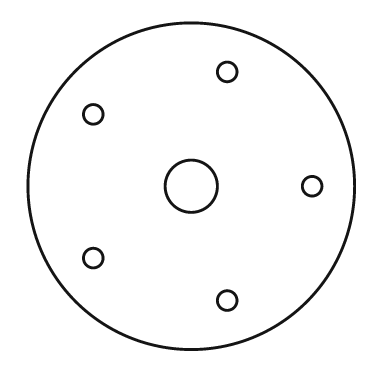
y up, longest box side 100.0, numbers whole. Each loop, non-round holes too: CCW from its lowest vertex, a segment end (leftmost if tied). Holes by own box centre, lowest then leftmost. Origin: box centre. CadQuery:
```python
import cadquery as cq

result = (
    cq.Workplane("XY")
    .moveTo(0.0, 0.0)
    .circle(50.0)
    .moveTo(11.0, -35.0)
    .circle(3.0)
    .moveTo(-30.0, -22.0)
    .circle(3.0)
    .moveTo(0.0, 0.0)
    .circle(8.0)
    .moveTo(37.0, 0.0)
    .circle(3.0)
    .moveTo(-30.0, 22.0)
    .circle(3.0)
    .moveTo(11.0, 35.0)
    .circle(3.0)
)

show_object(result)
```